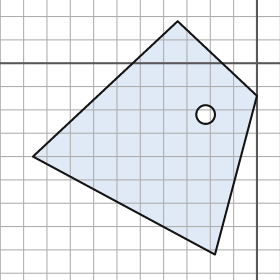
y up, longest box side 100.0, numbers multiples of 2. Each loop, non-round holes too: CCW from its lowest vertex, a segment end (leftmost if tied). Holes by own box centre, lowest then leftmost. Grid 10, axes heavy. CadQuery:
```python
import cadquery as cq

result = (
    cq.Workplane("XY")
    .moveTo(-18.0, -82.0)
    .lineTo(0.0, -14.0)
    .lineTo(-34.0, 18.0)
    .lineTo(-96.0, -40.0)
    .close()
    .moveTo(-22.0, -22.0)
    .circle(4.0)
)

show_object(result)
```